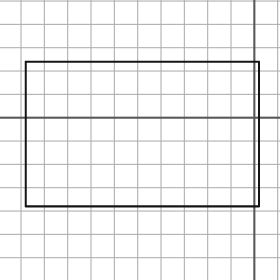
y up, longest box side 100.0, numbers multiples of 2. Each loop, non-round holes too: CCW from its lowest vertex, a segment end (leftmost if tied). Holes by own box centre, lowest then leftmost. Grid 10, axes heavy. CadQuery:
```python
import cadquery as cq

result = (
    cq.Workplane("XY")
    .moveTo(-98.0, -38.0)
    .lineTo(2.0, -38.0)
    .lineTo(2.0, 24.0)
    .lineTo(-98.0, 24.0)
    .close()
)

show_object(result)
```